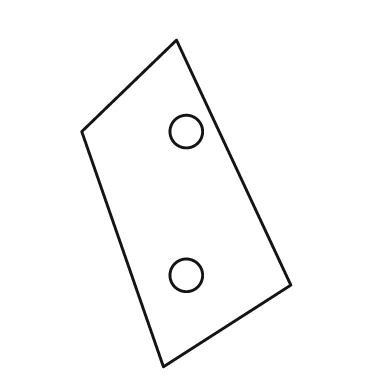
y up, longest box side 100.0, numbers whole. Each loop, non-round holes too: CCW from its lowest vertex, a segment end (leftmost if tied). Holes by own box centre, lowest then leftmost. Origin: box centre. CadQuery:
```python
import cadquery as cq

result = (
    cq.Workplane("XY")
    .moveTo(-7.0, -50.0)
    .lineTo(32.0, -25.0)
    .lineTo(-3.0, 50.0)
    .lineTo(-32.0, 22.0)
    .close()
    .moveTo(0.0, -22.0)
    .circle(5.0)
    .moveTo(0.0, 22.0)
    .circle(5.0)
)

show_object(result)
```